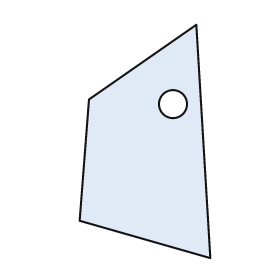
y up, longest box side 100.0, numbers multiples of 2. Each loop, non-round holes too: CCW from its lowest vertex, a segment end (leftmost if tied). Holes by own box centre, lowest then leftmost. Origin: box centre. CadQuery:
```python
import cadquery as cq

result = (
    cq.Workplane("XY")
    .moveTo(28.0, -50.0)
    .lineTo(22.0, 50.0)
    .lineTo(-24.0, 18.0)
    .lineTo(-28.0, -34.0)
    .close()
    .moveTo(12.0, 16.0)
    .circle(6.0)
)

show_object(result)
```